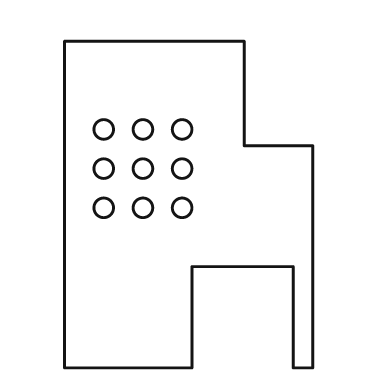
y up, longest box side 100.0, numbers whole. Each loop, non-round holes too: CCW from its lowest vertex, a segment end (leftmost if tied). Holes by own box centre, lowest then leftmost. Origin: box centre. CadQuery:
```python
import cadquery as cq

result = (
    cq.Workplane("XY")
    .moveTo(-38.0, -50.0)
    .lineTo(1.0, -50.0)
    .lineTo(1.0, -19.0)
    .lineTo(32.0, -19.0)
    .lineTo(32.0, -50.0)
    .lineTo(38.0, -50.0)
    .lineTo(38.0, 18.0)
    .lineTo(17.0, 18.0)
    .lineTo(17.0, 50.0)
    .lineTo(-38.0, 50.0)
    .close()
    .moveTo(-26.0, -1.0)
    .circle(3.0)
    .moveTo(-14.0, -1.0)
    .circle(3.0)
    .moveTo(-2.0, -1.0)
    .circle(3.0)
    .moveTo(-26.0, 11.0)
    .circle(3.0)
    .moveTo(-14.0, 11.0)
    .circle(3.0)
    .moveTo(-2.0, 11.0)
    .circle(3.0)
    .moveTo(-26.0, 23.0)
    .circle(3.0)
    .moveTo(-14.0, 23.0)
    .circle(3.0)
    .moveTo(-2.0, 23.0)
    .circle(3.0)
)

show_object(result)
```